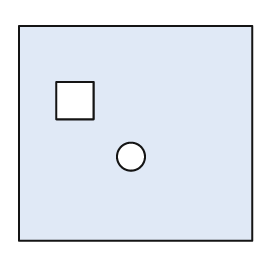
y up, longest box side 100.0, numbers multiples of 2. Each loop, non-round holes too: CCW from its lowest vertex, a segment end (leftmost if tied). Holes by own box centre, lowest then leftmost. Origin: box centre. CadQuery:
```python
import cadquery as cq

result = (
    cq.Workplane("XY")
    .moveTo(-50.0, -46.0)
    .lineTo(50.0, -46.0)
    .lineTo(50.0, 46.0)
    .lineTo(-50.0, 46.0)
    .close()
    .moveTo(-2.0, -10.0)
    .circle(6.0)
    .moveTo(-34.0, 6.0)
    .lineTo(-18.0, 6.0)
    .lineTo(-18.0, 22.0)
    .lineTo(-34.0, 22.0)
    .close()
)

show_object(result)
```